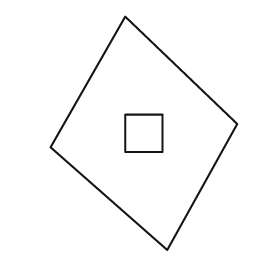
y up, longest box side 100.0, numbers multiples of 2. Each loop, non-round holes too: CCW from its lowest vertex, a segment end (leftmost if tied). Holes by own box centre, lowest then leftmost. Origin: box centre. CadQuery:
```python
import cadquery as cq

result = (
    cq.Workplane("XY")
    .moveTo(10.0, -50.0)
    .lineTo(40.0, 4.0)
    .lineTo(-8.0, 50.0)
    .lineTo(-40.0, -6.0)
    .close()
    .moveTo(-8.0, -8.0)
    .lineTo(8.0, -8.0)
    .lineTo(8.0, 8.0)
    .lineTo(-8.0, 8.0)
    .close()
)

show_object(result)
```